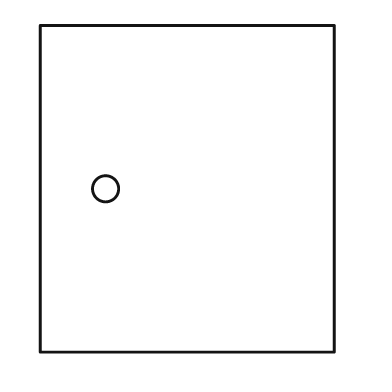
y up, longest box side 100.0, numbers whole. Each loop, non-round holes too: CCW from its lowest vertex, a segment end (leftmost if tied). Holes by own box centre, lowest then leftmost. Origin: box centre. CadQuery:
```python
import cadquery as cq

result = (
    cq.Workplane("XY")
    .moveTo(-45.0, -50.0)
    .lineTo(45.0, -50.0)
    .lineTo(45.0, 50.0)
    .lineTo(-45.0, 50.0)
    .close()
    .moveTo(-25.0, 0.0)
    .circle(4.0)
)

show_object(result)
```